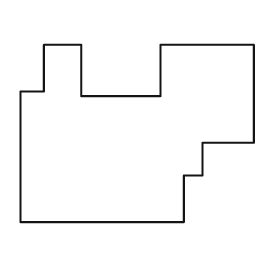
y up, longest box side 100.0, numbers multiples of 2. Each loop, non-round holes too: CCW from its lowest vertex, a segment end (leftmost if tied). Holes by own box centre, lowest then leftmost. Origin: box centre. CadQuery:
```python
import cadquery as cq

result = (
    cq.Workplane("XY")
    .moveTo(-50.0, -38.0)
    .lineTo(20.0, -38.0)
    .lineTo(20.0, -18.0)
    .lineTo(28.0, -18.0)
    .lineTo(28.0, -4.0)
    .lineTo(50.0, -4.0)
    .lineTo(50.0, 38.0)
    .lineTo(10.0, 38.0)
    .lineTo(10.0, 16.0)
    .lineTo(-24.0, 16.0)
    .lineTo(-24.0, 38.0)
    .lineTo(-40.0, 38.0)
    .lineTo(-40.0, 18.0)
    .lineTo(-50.0, 18.0)
    .close()
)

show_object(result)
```